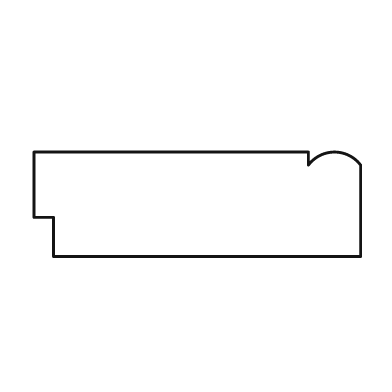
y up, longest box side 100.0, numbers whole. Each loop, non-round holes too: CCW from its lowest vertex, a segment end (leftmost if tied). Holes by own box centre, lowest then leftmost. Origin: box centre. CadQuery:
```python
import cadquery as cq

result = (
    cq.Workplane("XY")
    .moveTo(-44.0, -16.0)
    .lineTo(50.0, -16.0)
    .lineTo(50.0, 12.0)
    .threePointArc((42.0, 16.0), (34.0, 12.0))
    .lineTo(34.0, 16.0)
    .lineTo(-50.0, 16.0)
    .lineTo(-50.0, -4.0)
    .lineTo(-44.0, -4.0)
    .close()
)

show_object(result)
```